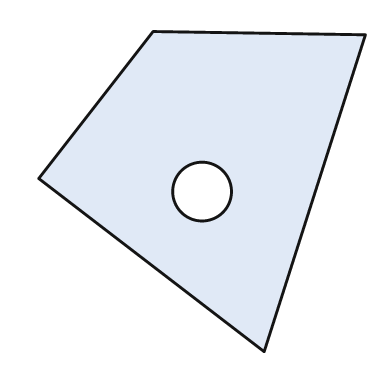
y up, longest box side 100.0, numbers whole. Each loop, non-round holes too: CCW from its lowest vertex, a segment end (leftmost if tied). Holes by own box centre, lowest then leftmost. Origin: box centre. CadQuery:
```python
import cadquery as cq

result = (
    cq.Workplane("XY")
    .moveTo(19.0, -49.0)
    .lineTo(50.0, 48.0)
    .lineTo(-15.0, 49.0)
    .lineTo(-50.0, 4.0)
    .close()
    .moveTo(0.0, 0.0)
    .circle(9.0)
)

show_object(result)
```